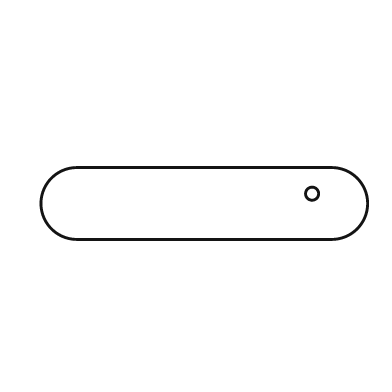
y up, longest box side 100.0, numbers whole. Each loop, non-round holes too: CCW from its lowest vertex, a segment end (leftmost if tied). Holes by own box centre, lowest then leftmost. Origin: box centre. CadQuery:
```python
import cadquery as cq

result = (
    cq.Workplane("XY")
    .moveTo(-39.0, -11.0)
    .lineTo(39.0, -11.0)
    .threePointArc((50.0, 0.0), (39.0, 11.0))
    .lineTo(-39.0, 11.0)
    .threePointArc((-50.0, 0.0), (-39.0, -11.0))
    .close()
    .moveTo(33.0, 3.0)
    .circle(2.0)
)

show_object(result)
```